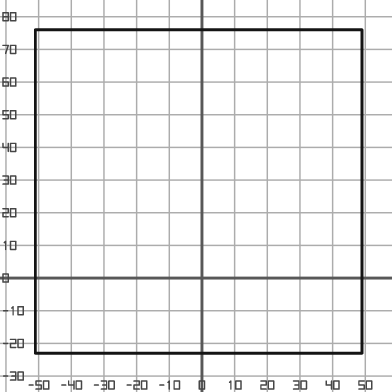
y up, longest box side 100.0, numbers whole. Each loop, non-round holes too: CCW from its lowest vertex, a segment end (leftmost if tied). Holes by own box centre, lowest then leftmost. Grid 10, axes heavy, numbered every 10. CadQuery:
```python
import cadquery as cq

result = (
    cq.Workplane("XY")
    .moveTo(-51.0, -23.0)
    .lineTo(49.0, -23.0)
    .lineTo(49.0, 76.0)
    .lineTo(-51.0, 76.0)
    .close()
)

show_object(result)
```